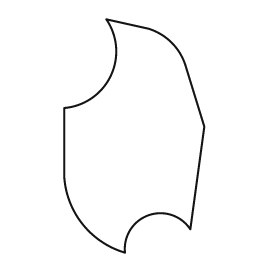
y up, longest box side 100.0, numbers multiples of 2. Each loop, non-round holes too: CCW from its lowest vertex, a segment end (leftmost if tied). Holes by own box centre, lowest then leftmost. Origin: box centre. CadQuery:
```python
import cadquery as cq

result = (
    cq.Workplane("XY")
    .moveTo(-4.0, -50.0)
    .threePointArc((6.0, -34.0), (24.0, -40.0))
    .lineTo(30.0, 4.0)
    .lineTo(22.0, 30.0)
    .threePointArc((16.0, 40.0), (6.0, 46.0))
    .lineTo(-12.0, 50.0)
    .threePointArc((-10.0, 26.0), (-30.0, 12.0))
    .lineTo(-30.0, -18.0)
    .threePointArc((-22.0, -38.0), (-4.0, -50.0))
    .close()
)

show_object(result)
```